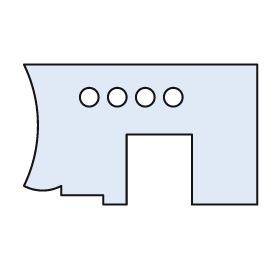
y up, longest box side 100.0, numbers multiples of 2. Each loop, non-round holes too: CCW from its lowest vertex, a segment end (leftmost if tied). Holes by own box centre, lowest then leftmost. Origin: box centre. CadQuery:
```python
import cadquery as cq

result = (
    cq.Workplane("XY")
    .moveTo(-16.0, -30.0)
    .lineTo(-6.0, -30.0)
    .lineTo(-6.0, 0.0)
    .lineTo(22.0, 0.0)
    .lineTo(22.0, -30.0)
    .lineTo(50.0, -30.0)
    .lineTo(50.0, 30.0)
    .lineTo(-50.0, 30.0)
    .threePointArc((-44.0, 4.0), (-50.0, -22.0))
    .threePointArc((-42.0, -24.0), (-34.0, -22.0))
    .lineTo(-34.0, -26.0)
    .lineTo(-16.0, -26.0)
    .close()
    .moveTo(-22.0, 16.0)
    .circle(4.0)
    .moveTo(-10.0, 16.0)
    .circle(4.0)
    .moveTo(2.0, 16.0)
    .circle(4.0)
    .moveTo(14.0, 16.0)
    .circle(4.0)
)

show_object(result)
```